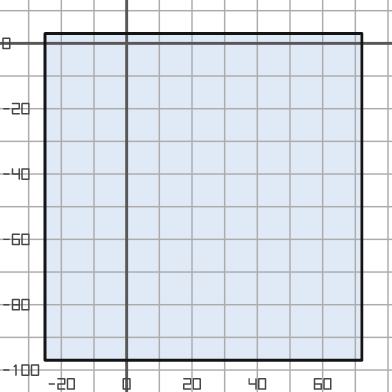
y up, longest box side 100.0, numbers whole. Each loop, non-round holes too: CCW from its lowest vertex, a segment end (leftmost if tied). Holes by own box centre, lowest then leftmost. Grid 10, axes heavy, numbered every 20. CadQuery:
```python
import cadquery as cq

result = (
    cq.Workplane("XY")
    .moveTo(-25.0, -97.0)
    .lineTo(72.0, -97.0)
    .lineTo(72.0, 3.0)
    .lineTo(-25.0, 3.0)
    .close()
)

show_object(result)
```